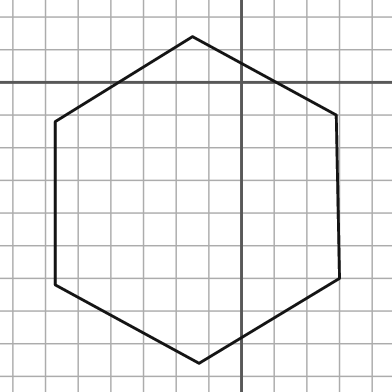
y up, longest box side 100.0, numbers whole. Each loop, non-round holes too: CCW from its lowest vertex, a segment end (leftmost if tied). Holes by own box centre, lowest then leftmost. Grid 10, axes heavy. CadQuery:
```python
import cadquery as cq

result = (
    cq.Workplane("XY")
    .moveTo(-13.0, -86.0)
    .lineTo(30.0, -60.0)
    .lineTo(29.0, -10.0)
    .lineTo(-15.0, 14.0)
    .lineTo(-57.0, -12.0)
    .lineTo(-57.0, -62.0)
    .close()
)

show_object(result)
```